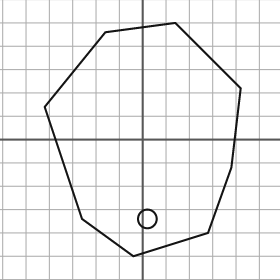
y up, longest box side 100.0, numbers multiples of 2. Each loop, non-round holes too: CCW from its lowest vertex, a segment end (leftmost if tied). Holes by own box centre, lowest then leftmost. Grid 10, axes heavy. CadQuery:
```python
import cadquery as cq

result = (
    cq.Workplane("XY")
    .moveTo(-4.0, -50.0)
    .lineTo(28.0, -40.0)
    .lineTo(38.0, -12.0)
    .lineTo(42.0, 22.0)
    .lineTo(14.0, 50.0)
    .lineTo(-16.0, 46.0)
    .lineTo(-42.0, 14.0)
    .lineTo(-26.0, -34.0)
    .close()
    .moveTo(2.0, -34.0)
    .circle(4.0)
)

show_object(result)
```